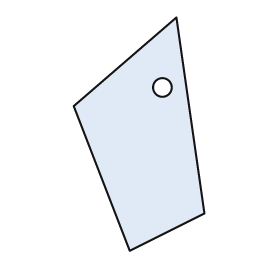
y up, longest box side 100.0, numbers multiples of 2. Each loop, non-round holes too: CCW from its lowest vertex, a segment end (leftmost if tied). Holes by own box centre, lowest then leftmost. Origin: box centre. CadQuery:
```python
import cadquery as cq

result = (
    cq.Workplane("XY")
    .moveTo(-4.0, -50.0)
    .lineTo(28.0, -34.0)
    .lineTo(16.0, 50.0)
    .lineTo(-28.0, 12.0)
    .close()
    .moveTo(10.0, 20.0)
    .circle(4.0)
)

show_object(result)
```